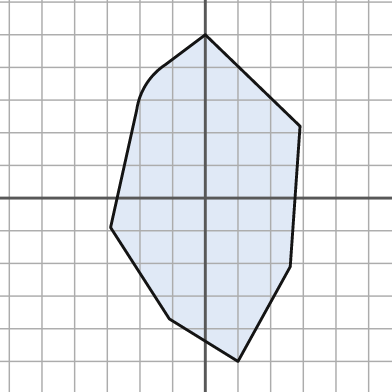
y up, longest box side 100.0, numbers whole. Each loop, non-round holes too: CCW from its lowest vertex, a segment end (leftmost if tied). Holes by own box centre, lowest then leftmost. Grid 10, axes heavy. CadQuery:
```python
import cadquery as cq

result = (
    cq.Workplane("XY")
    .moveTo(10.0, -50.0)
    .lineTo(26.0, -21.0)
    .lineTo(29.0, 22.0)
    .lineTo(0.0, 50.0)
    .lineTo(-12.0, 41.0)
    .threePointArc((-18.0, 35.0), (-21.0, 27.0))
    .lineTo(-29.0, -9.0)
    .lineTo(-11.0, -37.0)
    .close()
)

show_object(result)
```